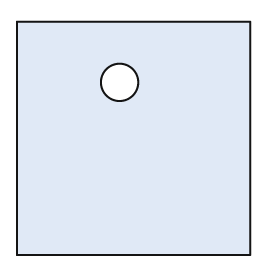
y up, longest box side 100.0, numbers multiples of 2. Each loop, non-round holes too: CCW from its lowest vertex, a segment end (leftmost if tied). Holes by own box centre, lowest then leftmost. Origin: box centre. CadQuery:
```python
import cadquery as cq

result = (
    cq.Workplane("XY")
    .moveTo(-50.0, -50.0)
    .lineTo(50.0, -50.0)
    .lineTo(50.0, 50.0)
    .lineTo(-50.0, 50.0)
    .close()
    .moveTo(-6.0, 24.0)
    .circle(8.0)
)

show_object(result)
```